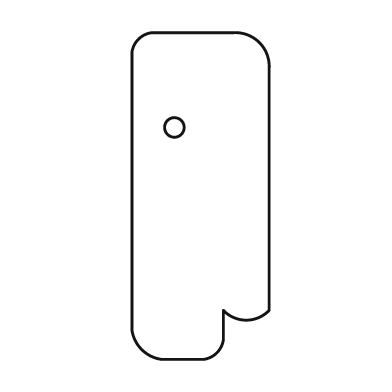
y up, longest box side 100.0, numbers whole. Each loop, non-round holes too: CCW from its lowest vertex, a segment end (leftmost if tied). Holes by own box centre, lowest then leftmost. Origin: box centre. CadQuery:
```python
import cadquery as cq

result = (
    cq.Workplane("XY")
    .moveTo(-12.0, -50.0)
    .lineTo(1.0, -50.0)
    .threePointArc((5.0, -48.0), (7.0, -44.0))
    .lineTo(7.0, -35.0)
    .threePointArc((14.0, -38.0), (21.0, -35.0))
    .lineTo(21.0, 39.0)
    .threePointArc((18.0, 47.0), (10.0, 50.0))
    .lineTo(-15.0, 50.0)
    .threePointArc((-19.0, 48.0), (-21.0, 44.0))
    .lineTo(-21.0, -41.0)
    .threePointArc((-18.0, -47.0), (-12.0, -50.0))
    .close()
    .moveTo(-8.0, 21.0)
    .circle(3.0)
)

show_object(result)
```